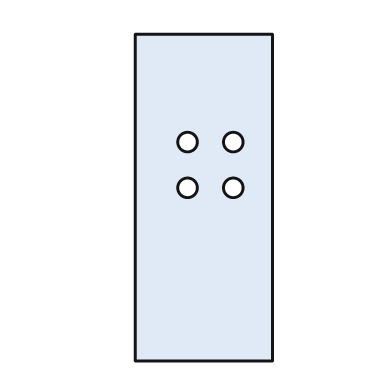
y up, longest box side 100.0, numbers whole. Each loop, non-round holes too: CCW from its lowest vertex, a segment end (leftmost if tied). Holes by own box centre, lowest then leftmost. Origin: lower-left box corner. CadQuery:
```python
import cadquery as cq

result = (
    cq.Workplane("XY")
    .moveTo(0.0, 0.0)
    .lineTo(42.0, 0.0)
    .lineTo(42.0, 100.0)
    .lineTo(0.0, 100.0)
    .close()
    .moveTo(16.0, 53.0)
    .circle(3.0)
    .moveTo(30.0, 53.0)
    .circle(3.0)
    .moveTo(16.0, 67.0)
    .circle(3.0)
    .moveTo(30.0, 67.0)
    .circle(3.0)
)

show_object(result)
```